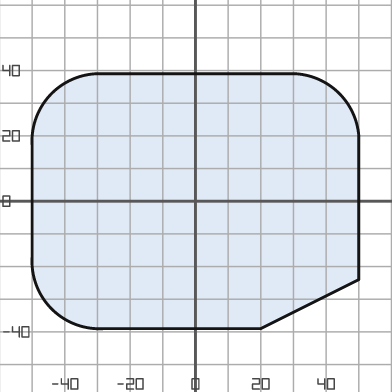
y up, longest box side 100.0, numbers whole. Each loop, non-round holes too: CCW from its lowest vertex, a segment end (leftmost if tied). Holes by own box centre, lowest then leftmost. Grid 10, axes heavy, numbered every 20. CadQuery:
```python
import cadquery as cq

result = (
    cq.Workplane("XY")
    .moveTo(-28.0, -39.0)
    .lineTo(20.0, -39.0)
    .lineTo(50.0, -24.0)
    .lineTo(50.0, 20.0)
    .threePointArc((44.0, 33.0), (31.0, 39.0))
    .lineTo(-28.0, 39.0)
    .threePointArc((-44.0, 33.0), (-50.0, 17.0))
    .lineTo(-50.0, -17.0)
    .threePointArc((-44.0, -33.0), (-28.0, -39.0))
    .close()
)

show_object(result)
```